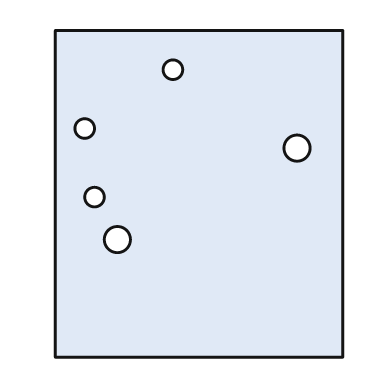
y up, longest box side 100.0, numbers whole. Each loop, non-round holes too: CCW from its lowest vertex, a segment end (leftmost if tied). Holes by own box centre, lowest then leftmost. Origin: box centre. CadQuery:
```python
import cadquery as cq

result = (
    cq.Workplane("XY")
    .moveTo(-44.0, -50.0)
    .lineTo(44.0, -50.0)
    .lineTo(44.0, 50.0)
    .lineTo(-44.0, 50.0)
    .close()
    .moveTo(-25.0, -14.0)
    .circle(4.0)
    .moveTo(-32.0, -1.0)
    .circle(3.0)
    .moveTo(30.0, 14.0)
    .circle(4.0)
    .moveTo(-35.0, 20.0)
    .circle(3.0)
    .moveTo(-8.0, 38.0)
    .circle(3.0)
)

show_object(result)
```